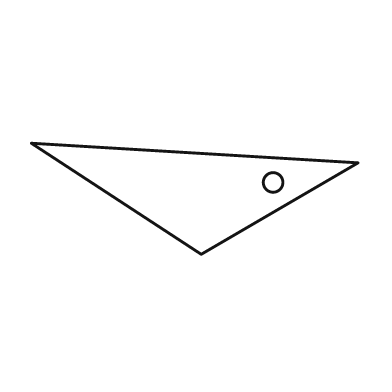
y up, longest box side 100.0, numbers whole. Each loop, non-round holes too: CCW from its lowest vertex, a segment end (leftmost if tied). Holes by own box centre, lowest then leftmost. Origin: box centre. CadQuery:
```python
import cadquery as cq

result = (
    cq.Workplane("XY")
    .moveTo(2.0, -17.0)
    .lineTo(50.0, 11.0)
    .lineTo(-50.0, 17.0)
    .close()
    .moveTo(24.0, 5.0)
    .circle(3.0)
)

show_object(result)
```